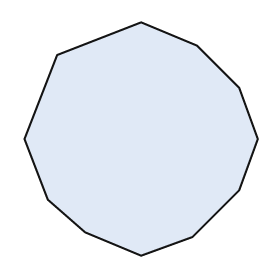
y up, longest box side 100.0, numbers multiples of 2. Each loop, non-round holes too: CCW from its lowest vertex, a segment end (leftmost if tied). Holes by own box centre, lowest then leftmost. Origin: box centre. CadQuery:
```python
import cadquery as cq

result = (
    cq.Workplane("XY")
    .moveTo(0.0, -50.0)
    .lineTo(22.0, -42.0)
    .lineTo(42.0, -22.0)
    .lineTo(50.0, 0.0)
    .lineTo(42.0, 22.0)
    .lineTo(24.0, 40.0)
    .lineTo(0.0, 50.0)
    .lineTo(-36.0, 36.0)
    .lineTo(-50.0, 0.0)
    .lineTo(-40.0, -26.0)
    .lineTo(-24.0, -40.0)
    .close()
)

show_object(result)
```